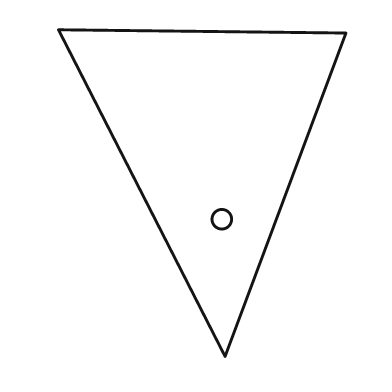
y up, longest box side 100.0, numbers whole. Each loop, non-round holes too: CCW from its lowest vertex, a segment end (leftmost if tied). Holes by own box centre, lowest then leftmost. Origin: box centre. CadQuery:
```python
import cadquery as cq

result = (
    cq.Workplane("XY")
    .moveTo(7.0, -50.0)
    .lineTo(44.0, 49.0)
    .lineTo(-44.0, 50.0)
    .close()
    .moveTo(6.0, -8.0)
    .circle(3.0)
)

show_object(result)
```